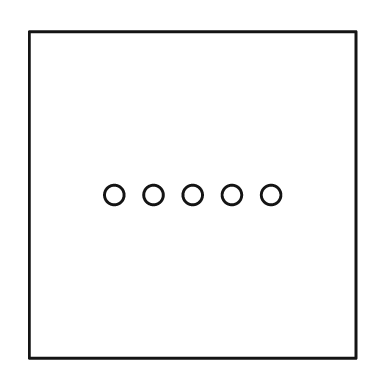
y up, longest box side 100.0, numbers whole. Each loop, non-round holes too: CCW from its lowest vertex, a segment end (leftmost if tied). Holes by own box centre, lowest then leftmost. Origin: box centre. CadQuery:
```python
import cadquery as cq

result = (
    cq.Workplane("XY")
    .moveTo(-50.0, -50.0)
    .lineTo(50.0, -50.0)
    .lineTo(50.0, 50.0)
    .lineTo(-50.0, 50.0)
    .close()
    .moveTo(-24.0, 0.0)
    .circle(3.0)
    .moveTo(-12.0, 0.0)
    .circle(3.0)
    .moveTo(0.0, 0.0)
    .circle(3.0)
    .moveTo(12.0, 0.0)
    .circle(3.0)
    .moveTo(24.0, 0.0)
    .circle(3.0)
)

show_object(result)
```